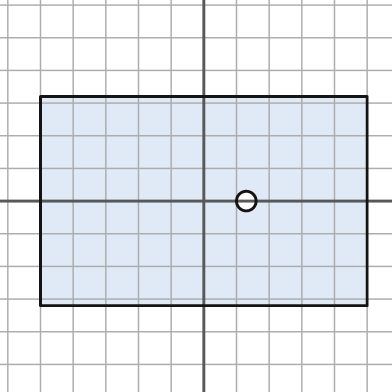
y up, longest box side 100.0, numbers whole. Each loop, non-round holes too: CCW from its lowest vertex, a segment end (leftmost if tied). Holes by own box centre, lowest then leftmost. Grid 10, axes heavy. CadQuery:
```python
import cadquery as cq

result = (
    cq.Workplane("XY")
    .moveTo(-50.0, -32.0)
    .lineTo(50.0, -32.0)
    .lineTo(50.0, 32.0)
    .lineTo(-50.0, 32.0)
    .close()
    .moveTo(13.0, 0.0)
    .circle(3.0)
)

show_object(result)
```